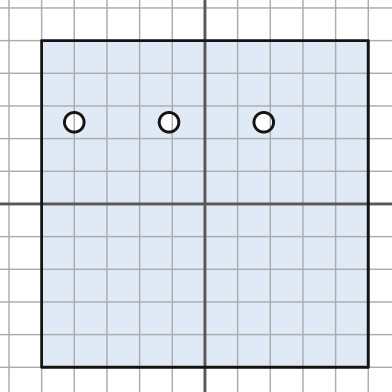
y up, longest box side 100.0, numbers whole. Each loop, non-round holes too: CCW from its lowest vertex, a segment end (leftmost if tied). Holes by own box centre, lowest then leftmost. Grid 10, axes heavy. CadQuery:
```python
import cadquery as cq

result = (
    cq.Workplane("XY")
    .moveTo(-50.0, -50.0)
    .lineTo(50.0, -50.0)
    .lineTo(50.0, 50.0)
    .lineTo(-50.0, 50.0)
    .close()
    .moveTo(-40.0, 25.0)
    .circle(3.0)
    .moveTo(-11.0, 25.0)
    .circle(3.0)
    .moveTo(18.0, 25.0)
    .circle(3.0)
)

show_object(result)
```